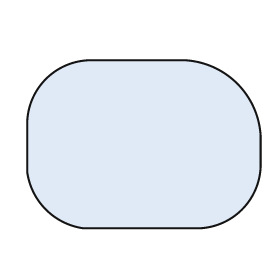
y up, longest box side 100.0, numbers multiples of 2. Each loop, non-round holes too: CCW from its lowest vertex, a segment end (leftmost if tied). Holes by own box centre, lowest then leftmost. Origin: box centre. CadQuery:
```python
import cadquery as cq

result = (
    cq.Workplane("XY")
    .moveTo(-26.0, -36.0)
    .lineTo(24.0, -36.0)
    .threePointArc((42.0, -28.0), (50.0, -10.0))
    .lineTo(50.0, 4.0)
    .threePointArc((40.0, 26.0), (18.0, 36.0))
    .lineTo(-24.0, 36.0)
    .threePointArc((-42.0, 28.0), (-50.0, 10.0))
    .lineTo(-50.0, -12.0)
    .threePointArc((-42.0, -28.0), (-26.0, -36.0))
    .close()
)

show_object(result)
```